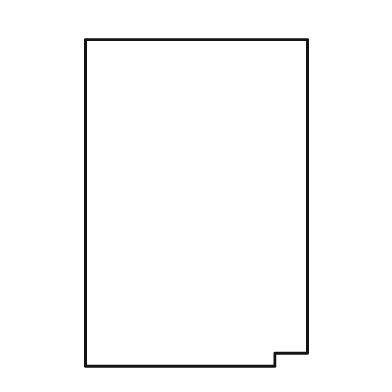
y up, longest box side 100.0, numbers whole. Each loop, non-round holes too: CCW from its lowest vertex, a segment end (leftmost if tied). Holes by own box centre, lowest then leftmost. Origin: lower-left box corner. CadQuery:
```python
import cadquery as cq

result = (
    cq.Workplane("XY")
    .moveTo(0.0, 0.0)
    .lineTo(58.0, 0.0)
    .lineTo(58.0, 4.0)
    .lineTo(68.0, 4.0)
    .lineTo(68.0, 100.0)
    .lineTo(0.0, 100.0)
    .close()
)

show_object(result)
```